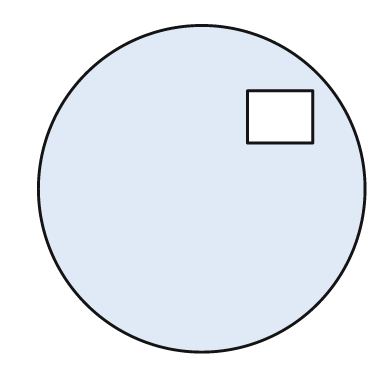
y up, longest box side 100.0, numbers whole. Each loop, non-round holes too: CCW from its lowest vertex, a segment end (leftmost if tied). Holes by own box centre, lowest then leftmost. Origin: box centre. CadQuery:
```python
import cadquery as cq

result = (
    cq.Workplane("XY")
    .moveTo(0.0, 0.0)
    .circle(50.0)
    .moveTo(14.0, 14.0)
    .lineTo(34.0, 14.0)
    .lineTo(34.0, 30.0)
    .lineTo(14.0, 30.0)
    .close()
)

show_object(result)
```